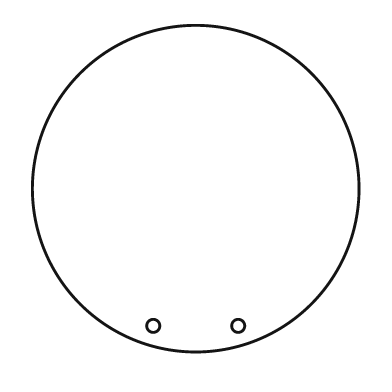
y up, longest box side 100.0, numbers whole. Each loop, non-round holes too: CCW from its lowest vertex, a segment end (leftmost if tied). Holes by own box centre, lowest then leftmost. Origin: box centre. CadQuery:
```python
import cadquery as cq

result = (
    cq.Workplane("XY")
    .moveTo(0.0, 0.0)
    .circle(50.0)
    .moveTo(-13.0, -42.0)
    .circle(2.0)
    .moveTo(13.0, -42.0)
    .circle(2.0)
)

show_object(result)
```